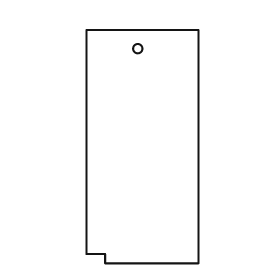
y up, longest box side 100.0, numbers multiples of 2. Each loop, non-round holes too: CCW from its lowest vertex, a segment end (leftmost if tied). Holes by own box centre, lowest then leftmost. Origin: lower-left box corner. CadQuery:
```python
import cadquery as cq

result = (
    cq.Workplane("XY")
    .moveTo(8.0, 0.0)
    .lineTo(48.0, 0.0)
    .lineTo(48.0, 100.0)
    .lineTo(0.0, 100.0)
    .lineTo(0.0, 4.0)
    .lineTo(8.0, 4.0)
    .close()
    .moveTo(22.0, 92.0)
    .circle(2.0)
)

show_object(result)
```